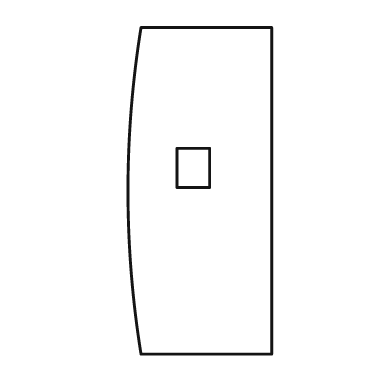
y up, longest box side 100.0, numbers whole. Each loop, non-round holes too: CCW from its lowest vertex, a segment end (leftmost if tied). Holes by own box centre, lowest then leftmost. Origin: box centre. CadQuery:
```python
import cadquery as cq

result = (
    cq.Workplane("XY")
    .moveTo(-18.0, -50.0)
    .lineTo(22.0, -50.0)
    .lineTo(22.0, 50.0)
    .lineTo(-18.0, 50.0)
    .threePointArc((-22.0, 0.0), (-18.0, -50.0))
    .close()
    .moveTo(-7.0, 1.0)
    .lineTo(3.0, 1.0)
    .lineTo(3.0, 13.0)
    .lineTo(-7.0, 13.0)
    .close()
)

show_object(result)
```